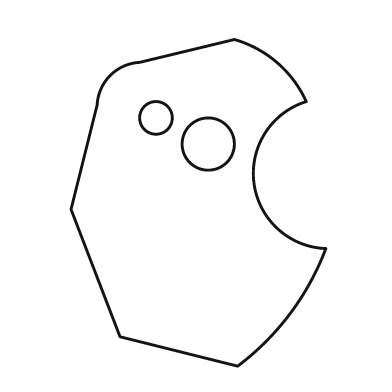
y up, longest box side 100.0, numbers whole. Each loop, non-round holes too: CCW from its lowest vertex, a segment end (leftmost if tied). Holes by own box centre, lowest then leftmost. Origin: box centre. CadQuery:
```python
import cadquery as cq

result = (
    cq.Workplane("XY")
    .moveTo(12.0, -50.0)
    .threePointArc((28.0, -34.0), (39.0, -14.0))
    .threePointArc((17.0, 6.0), (33.0, 31.0))
    .threePointArc((24.0, 43.0), (11.0, 50.0))
    .lineTo(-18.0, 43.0)
    .threePointArc((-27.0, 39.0), (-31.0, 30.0))
    .lineTo(-39.0, -2.0)
    .lineTo(-24.0, -41.0)
    .close()
    .moveTo(3.0, 18.0)
    .circle(8.0)
    .moveTo(-13.0, 26.0)
    .circle(5.0)
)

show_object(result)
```